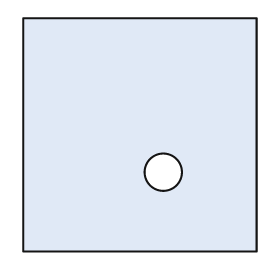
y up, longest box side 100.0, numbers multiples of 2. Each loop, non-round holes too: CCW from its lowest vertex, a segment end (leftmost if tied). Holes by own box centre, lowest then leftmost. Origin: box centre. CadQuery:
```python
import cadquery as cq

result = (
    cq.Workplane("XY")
    .moveTo(-50.0, -50.0)
    .lineTo(50.0, -50.0)
    .lineTo(50.0, 50.0)
    .lineTo(-50.0, 50.0)
    .close()
    .moveTo(10.0, -16.0)
    .circle(8.0)
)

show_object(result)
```